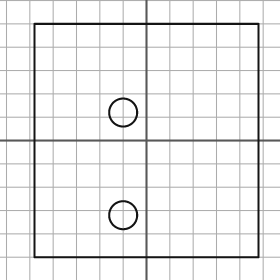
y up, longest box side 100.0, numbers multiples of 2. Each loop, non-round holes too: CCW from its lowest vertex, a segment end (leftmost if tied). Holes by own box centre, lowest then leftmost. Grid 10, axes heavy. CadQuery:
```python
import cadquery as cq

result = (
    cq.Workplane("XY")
    .moveTo(-48.0, -50.0)
    .lineTo(48.0, -50.0)
    .lineTo(48.0, 50.0)
    .lineTo(-48.0, 50.0)
    .close()
    .moveTo(-10.0, -32.0)
    .circle(6.0)
    .moveTo(-10.0, 12.0)
    .circle(6.0)
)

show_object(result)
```